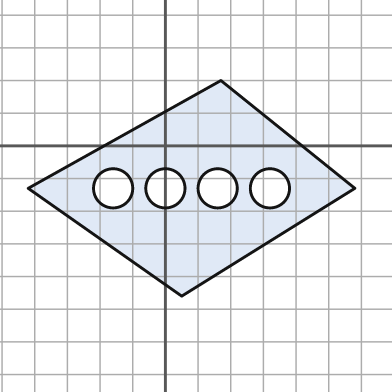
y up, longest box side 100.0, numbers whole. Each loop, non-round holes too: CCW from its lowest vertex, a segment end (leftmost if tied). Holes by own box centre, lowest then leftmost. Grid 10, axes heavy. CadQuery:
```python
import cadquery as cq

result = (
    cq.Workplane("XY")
    .moveTo(5.0, -46.0)
    .lineTo(58.0, -13.0)
    .lineTo(17.0, 20.0)
    .lineTo(-42.0, -13.0)
    .close()
    .moveTo(-16.0, -13.0)
    .circle(6.0)
    .moveTo(0.0, -13.0)
    .circle(6.0)
    .moveTo(16.0, -13.0)
    .circle(6.0)
    .moveTo(32.0, -13.0)
    .circle(6.0)
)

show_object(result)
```